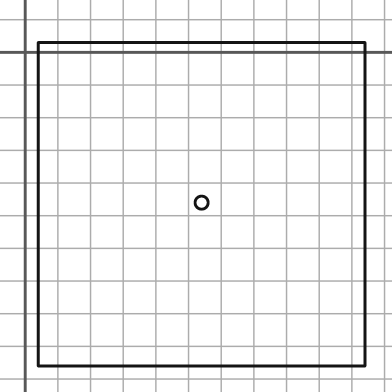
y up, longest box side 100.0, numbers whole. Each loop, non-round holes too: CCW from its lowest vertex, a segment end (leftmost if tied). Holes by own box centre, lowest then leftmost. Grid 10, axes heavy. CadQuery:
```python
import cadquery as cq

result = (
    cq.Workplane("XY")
    .moveTo(4.0, -96.0)
    .lineTo(104.0, -96.0)
    .lineTo(104.0, 3.0)
    .lineTo(4.0, 3.0)
    .close()
    .moveTo(54.0, -46.0)
    .circle(2.0)
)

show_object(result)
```